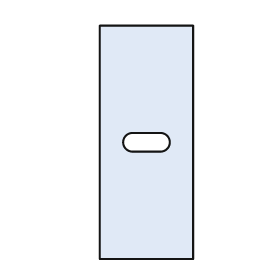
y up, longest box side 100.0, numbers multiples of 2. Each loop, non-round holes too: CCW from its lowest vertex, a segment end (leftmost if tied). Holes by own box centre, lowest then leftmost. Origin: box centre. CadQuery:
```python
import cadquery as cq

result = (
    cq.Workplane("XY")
    .moveTo(-20.0, -50.0)
    .lineTo(20.0, -50.0)
    .lineTo(20.0, 50.0)
    .lineTo(-20.0, 50.0)
    .close()
    .moveTo(-6.0, -4.0)
    .lineTo(6.0, -4.0)
    .threePointArc((10.0, 0.0), (6.0, 4.0))
    .lineTo(-6.0, 4.0)
    .threePointArc((-10.0, 0.0), (-6.0, -4.0))
    .close()
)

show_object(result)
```